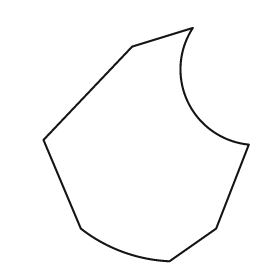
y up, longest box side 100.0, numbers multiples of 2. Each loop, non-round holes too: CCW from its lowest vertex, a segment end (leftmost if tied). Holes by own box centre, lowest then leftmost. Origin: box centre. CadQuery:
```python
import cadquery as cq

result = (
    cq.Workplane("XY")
    .moveTo(10.0, -50.0)
    .lineTo(30.0, -36.0)
    .lineTo(44.0, 0.0)
    .threePointArc((18.0, 18.0), (20.0, 50.0))
    .lineTo(-6.0, 42.0)
    .lineTo(-44.0, 2.0)
    .lineTo(-28.0, -36.0)
    .threePointArc((-10.0, -46.0), (10.0, -50.0))
    .close()
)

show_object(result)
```